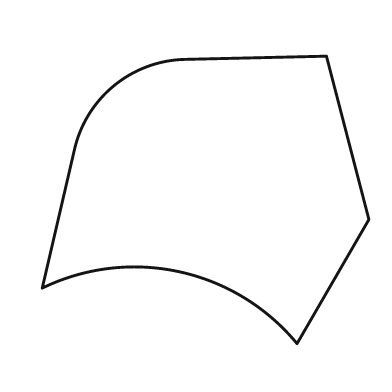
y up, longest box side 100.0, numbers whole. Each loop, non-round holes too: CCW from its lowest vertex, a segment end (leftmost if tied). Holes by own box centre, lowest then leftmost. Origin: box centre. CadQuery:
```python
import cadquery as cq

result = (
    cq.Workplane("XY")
    .moveTo(28.0, -44.0)
    .lineTo(50.0, -6.0)
    .lineTo(37.0, 44.0)
    .lineTo(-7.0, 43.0)
    .threePointArc((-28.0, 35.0), (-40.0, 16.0))
    .lineTo(-50.0, -27.0)
    .threePointArc((-8.0, -22.0), (28.0, -44.0))
    .close()
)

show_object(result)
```